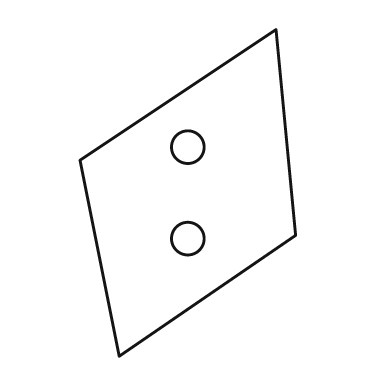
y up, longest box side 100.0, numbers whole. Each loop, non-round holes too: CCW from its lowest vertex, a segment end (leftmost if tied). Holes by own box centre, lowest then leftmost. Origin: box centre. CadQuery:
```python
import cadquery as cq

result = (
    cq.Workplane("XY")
    .moveTo(-21.0, -50.0)
    .lineTo(33.0, -13.0)
    .lineTo(27.0, 50.0)
    .lineTo(-33.0, 10.0)
    .close()
    .moveTo(0.0, -14.0)
    .circle(5.0)
    .moveTo(0.0, 14.0)
    .circle(5.0)
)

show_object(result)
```